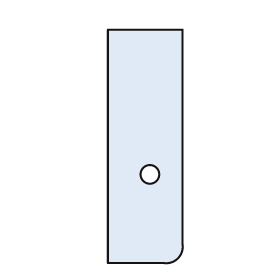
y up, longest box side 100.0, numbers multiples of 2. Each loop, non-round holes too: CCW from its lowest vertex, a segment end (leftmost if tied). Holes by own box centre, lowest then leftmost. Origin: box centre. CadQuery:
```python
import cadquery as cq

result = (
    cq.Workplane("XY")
    .moveTo(-16.0, -50.0)
    .lineTo(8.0, -50.0)
    .threePointArc((14.0, -48.0), (16.0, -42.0))
    .lineTo(16.0, 50.0)
    .lineTo(-16.0, 50.0)
    .close()
    .moveTo(2.0, -12.0)
    .circle(4.0)
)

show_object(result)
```